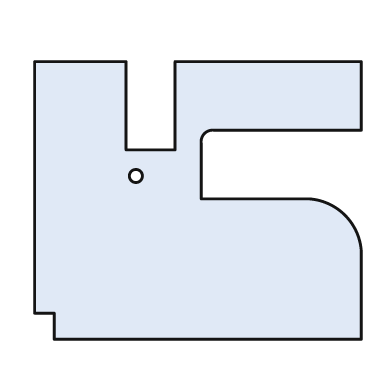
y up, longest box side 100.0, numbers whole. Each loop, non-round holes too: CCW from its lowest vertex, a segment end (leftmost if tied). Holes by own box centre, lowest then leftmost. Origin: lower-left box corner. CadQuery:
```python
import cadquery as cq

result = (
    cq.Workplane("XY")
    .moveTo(6.0, 0.0)
    .lineTo(100.0, 0.0)
    .lineTo(100.0, 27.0)
    .threePointArc((95.0, 38.0), (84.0, 43.0))
    .lineTo(51.0, 43.0)
    .lineTo(51.0, 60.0)
    .threePointArc((52.0, 63.0), (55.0, 64.0))
    .lineTo(100.0, 64.0)
    .lineTo(100.0, 85.0)
    .lineTo(43.0, 85.0)
    .lineTo(43.0, 58.0)
    .lineTo(28.0, 58.0)
    .lineTo(28.0, 85.0)
    .lineTo(0.0, 85.0)
    .lineTo(0.0, 8.0)
    .lineTo(6.0, 8.0)
    .close()
    .moveTo(31.0, 50.0)
    .circle(2.0)
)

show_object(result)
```